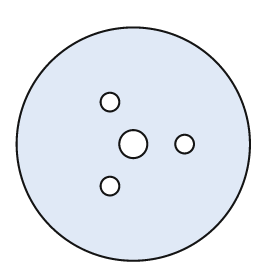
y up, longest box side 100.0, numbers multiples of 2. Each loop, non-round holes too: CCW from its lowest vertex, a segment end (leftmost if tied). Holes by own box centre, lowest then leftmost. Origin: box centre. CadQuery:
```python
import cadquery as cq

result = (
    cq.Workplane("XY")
    .moveTo(0.0, 0.0)
    .circle(50.0)
    .moveTo(-10.0, -18.0)
    .circle(4.0)
    .moveTo(0.0, 0.0)
    .circle(6.0)
    .moveTo(22.0, 0.0)
    .circle(4.0)
    .moveTo(-10.0, 18.0)
    .circle(4.0)
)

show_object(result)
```